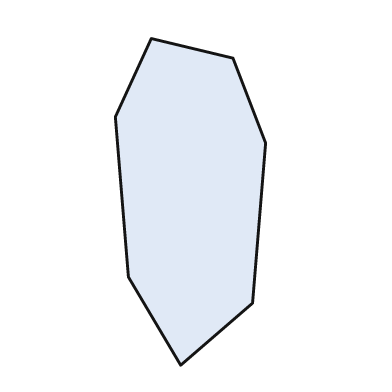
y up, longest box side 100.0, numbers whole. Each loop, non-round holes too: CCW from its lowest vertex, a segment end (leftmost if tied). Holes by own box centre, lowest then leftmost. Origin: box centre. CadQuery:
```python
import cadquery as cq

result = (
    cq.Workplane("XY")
    .moveTo(-3.0, -50.0)
    .lineTo(19.0, -31.0)
    .lineTo(23.0, 18.0)
    .lineTo(13.0, 44.0)
    .lineTo(-12.0, 50.0)
    .lineTo(-23.0, 26.0)
    .lineTo(-19.0, -23.0)
    .close()
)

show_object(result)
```